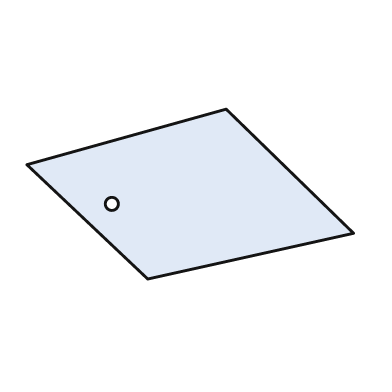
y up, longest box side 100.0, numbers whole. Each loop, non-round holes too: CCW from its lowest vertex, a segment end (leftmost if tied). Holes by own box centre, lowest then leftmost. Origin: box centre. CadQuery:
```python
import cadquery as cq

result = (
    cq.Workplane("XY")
    .moveTo(-13.0, -26.0)
    .lineTo(50.0, -12.0)
    .lineTo(11.0, 26.0)
    .lineTo(-50.0, 9.0)
    .close()
    .moveTo(-24.0, -3.0)
    .circle(2.0)
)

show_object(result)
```